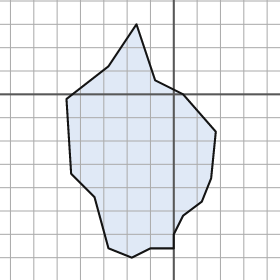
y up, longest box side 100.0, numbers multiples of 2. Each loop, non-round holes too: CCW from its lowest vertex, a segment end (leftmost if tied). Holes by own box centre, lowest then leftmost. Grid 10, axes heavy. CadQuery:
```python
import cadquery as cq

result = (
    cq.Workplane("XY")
    .moveTo(-18.0, -70.0)
    .lineTo(-10.0, -66.0)
    .lineTo(0.0, -66.0)
    .lineTo(0.0, -60.0)
    .lineTo(4.0, -52.0)
    .lineTo(12.0, -46.0)
    .lineTo(16.0, -36.0)
    .lineTo(18.0, -16.0)
    .lineTo(4.0, 0.0)
    .lineTo(-8.0, 6.0)
    .lineTo(-16.0, 30.0)
    .lineTo(-28.0, 12.0)
    .lineTo(-46.0, -2.0)
    .lineTo(-44.0, -34.0)
    .lineTo(-34.0, -44.0)
    .lineTo(-28.0, -66.0)
    .close()
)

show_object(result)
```